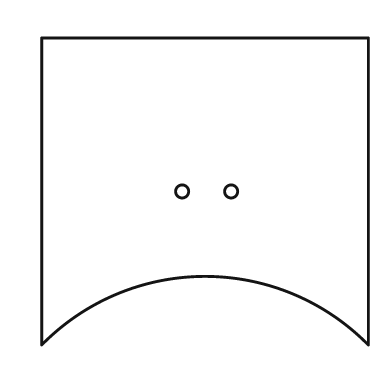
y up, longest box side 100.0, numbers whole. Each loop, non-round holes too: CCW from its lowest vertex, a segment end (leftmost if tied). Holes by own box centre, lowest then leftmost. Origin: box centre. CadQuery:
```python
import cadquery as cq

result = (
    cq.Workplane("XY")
    .moveTo(-50.0, -47.0)
    .threePointArc((0.0, -26.0), (50.0, -47.0))
    .lineTo(50.0, 47.0)
    .lineTo(-50.0, 47.0)
    .close()
    .moveTo(-7.0, 0.0)
    .circle(2.0)
    .moveTo(8.0, 0.0)
    .circle(2.0)
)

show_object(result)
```